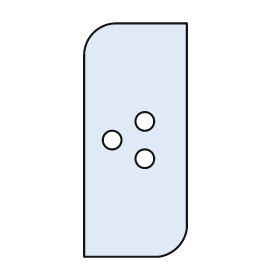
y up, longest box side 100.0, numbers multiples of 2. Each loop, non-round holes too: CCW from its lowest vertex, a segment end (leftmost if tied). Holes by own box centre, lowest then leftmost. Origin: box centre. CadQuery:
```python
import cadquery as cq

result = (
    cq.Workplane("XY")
    .moveTo(-22.0, -50.0)
    .lineTo(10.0, -50.0)
    .threePointArc((18.0, -46.0), (22.0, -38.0))
    .lineTo(22.0, 50.0)
    .lineTo(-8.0, 50.0)
    .threePointArc((-18.0, 46.0), (-22.0, 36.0))
    .close()
    .moveTo(4.0, -8.0)
    .circle(4.0)
    .moveTo(-10.0, 0.0)
    .circle(4.0)
    .moveTo(4.0, 8.0)
    .circle(4.0)
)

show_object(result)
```